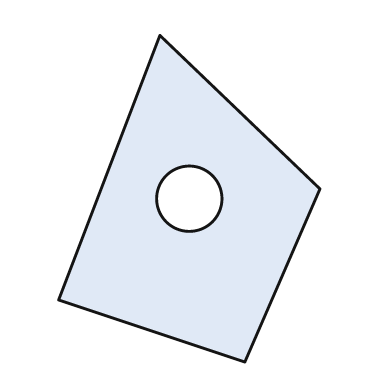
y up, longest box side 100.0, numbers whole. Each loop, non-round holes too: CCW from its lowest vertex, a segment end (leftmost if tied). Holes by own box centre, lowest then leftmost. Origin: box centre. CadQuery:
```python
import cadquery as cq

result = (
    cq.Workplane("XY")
    .moveTo(17.0, -50.0)
    .lineTo(40.0, 3.0)
    .lineTo(-9.0, 50.0)
    .lineTo(-40.0, -31.0)
    .close()
    .moveTo(0.0, 0.0)
    .circle(10.0)
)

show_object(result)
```